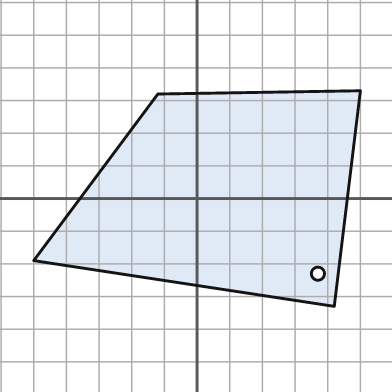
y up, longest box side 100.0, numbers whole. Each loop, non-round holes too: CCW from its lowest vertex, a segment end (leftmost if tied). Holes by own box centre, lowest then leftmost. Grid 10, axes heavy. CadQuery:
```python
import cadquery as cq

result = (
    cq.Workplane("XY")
    .moveTo(42.0, -33.0)
    .lineTo(50.0, 33.0)
    .lineTo(-12.0, 32.0)
    .lineTo(-50.0, -19.0)
    .close()
    .moveTo(37.0, -23.0)
    .circle(2.0)
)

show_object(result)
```